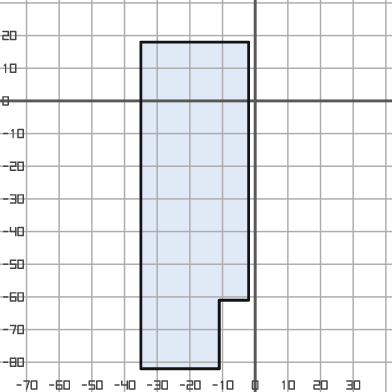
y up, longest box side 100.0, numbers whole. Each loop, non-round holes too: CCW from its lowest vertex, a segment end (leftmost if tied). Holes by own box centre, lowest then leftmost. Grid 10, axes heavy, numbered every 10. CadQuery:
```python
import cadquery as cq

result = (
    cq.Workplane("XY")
    .moveTo(-35.0, -82.0)
    .lineTo(-11.0, -82.0)
    .lineTo(-11.0, -61.0)
    .lineTo(-2.0, -61.0)
    .lineTo(-2.0, 18.0)
    .lineTo(-35.0, 18.0)
    .close()
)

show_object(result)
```